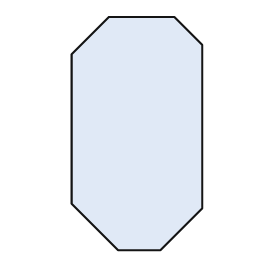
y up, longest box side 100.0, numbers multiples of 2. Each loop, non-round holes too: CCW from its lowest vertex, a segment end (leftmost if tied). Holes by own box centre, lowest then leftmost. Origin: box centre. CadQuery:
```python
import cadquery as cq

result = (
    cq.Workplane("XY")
    .moveTo(-8.0, -50.0)
    .lineTo(10.0, -50.0)
    .lineTo(28.0, -32.0)
    .lineTo(28.0, 38.0)
    .lineTo(16.0, 50.0)
    .lineTo(-12.0, 50.0)
    .lineTo(-28.0, 34.0)
    .lineTo(-28.0, -30.0)
    .close()
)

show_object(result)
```